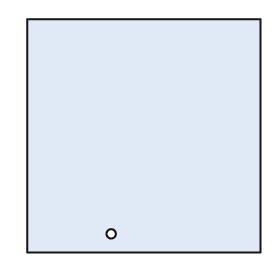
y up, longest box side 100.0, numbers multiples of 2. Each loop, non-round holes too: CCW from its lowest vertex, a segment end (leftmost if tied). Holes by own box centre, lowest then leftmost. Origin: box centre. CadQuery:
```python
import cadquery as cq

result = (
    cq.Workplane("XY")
    .moveTo(-50.0, -50.0)
    .lineTo(50.0, -50.0)
    .lineTo(50.0, 50.0)
    .lineTo(-50.0, 50.0)
    .close()
    .moveTo(-14.0, -42.0)
    .circle(2.0)
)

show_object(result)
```